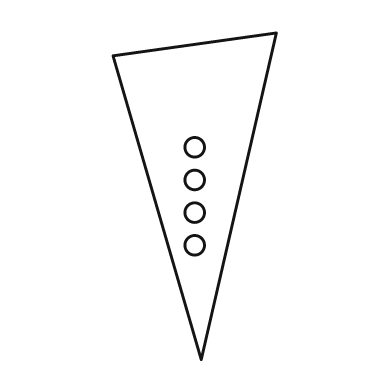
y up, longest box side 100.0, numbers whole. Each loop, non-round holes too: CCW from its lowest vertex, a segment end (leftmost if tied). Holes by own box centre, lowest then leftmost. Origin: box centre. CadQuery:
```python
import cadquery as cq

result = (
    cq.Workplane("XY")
    .moveTo(2.0, -50.0)
    .lineTo(25.0, 50.0)
    .lineTo(-25.0, 43.0)
    .close()
    .moveTo(0.0, -15.0)
    .circle(3.0)
    .moveTo(0.0, -5.0)
    .circle(3.0)
    .moveTo(0.0, 5.0)
    .circle(3.0)
    .moveTo(0.0, 15.0)
    .circle(3.0)
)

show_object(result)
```